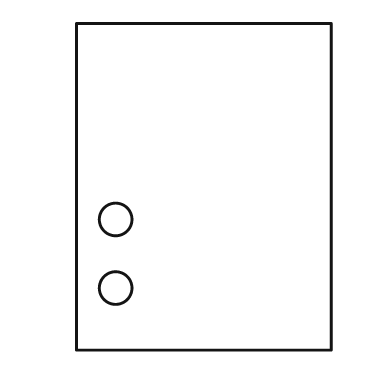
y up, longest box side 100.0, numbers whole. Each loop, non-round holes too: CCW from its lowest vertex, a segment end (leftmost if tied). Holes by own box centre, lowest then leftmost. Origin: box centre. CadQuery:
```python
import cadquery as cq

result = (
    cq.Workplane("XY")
    .moveTo(-39.0, -50.0)
    .lineTo(39.0, -50.0)
    .lineTo(39.0, 50.0)
    .lineTo(-39.0, 50.0)
    .close()
    .moveTo(-27.0, -31.0)
    .circle(5.0)
    .moveTo(-27.0, -10.0)
    .circle(5.0)
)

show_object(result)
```